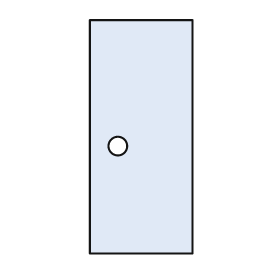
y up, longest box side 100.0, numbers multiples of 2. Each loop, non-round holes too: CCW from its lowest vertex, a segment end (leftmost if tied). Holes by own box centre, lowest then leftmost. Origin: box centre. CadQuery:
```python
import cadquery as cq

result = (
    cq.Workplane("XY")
    .moveTo(-22.0, -50.0)
    .lineTo(22.0, -50.0)
    .lineTo(22.0, 50.0)
    .lineTo(-22.0, 50.0)
    .close()
    .moveTo(-10.0, -4.0)
    .circle(4.0)
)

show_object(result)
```